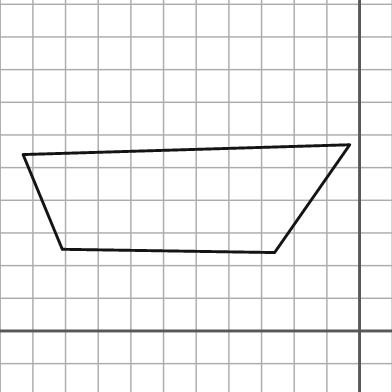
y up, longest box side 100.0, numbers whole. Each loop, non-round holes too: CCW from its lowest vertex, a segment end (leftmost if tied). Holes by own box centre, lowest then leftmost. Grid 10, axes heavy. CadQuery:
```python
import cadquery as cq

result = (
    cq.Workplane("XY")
    .moveTo(-26.0, 24.0)
    .lineTo(-3.0, 57.0)
    .lineTo(-103.0, 54.0)
    .lineTo(-91.0, 25.0)
    .close()
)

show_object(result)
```